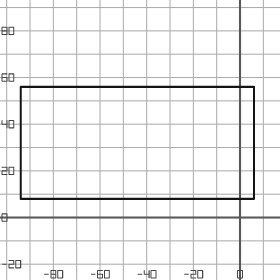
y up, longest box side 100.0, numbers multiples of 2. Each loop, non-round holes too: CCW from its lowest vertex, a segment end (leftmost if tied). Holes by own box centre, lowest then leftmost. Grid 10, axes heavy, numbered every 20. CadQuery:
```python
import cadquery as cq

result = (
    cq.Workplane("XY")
    .moveTo(-94.0, 8.0)
    .lineTo(6.0, 8.0)
    .lineTo(6.0, 56.0)
    .lineTo(-94.0, 56.0)
    .close()
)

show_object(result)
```